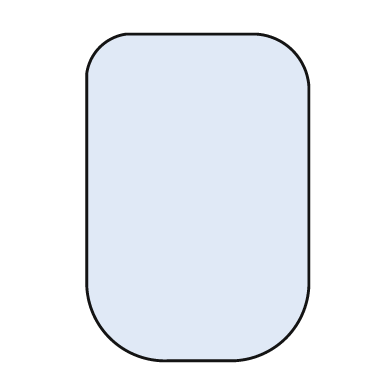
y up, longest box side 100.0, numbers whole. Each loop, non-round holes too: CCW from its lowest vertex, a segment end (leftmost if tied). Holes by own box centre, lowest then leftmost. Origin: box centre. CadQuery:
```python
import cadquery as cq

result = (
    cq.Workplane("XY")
    .moveTo(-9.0, -50.0)
    .lineTo(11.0, -50.0)
    .threePointArc((27.0, -43.0), (34.0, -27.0))
    .lineTo(34.0, 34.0)
    .threePointArc((29.0, 45.0), (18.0, 50.0))
    .lineTo(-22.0, 50.0)
    .threePointArc((-30.0, 46.0), (-34.0, 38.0))
    .lineTo(-34.0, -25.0)
    .threePointArc((-27.0, -43.0), (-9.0, -50.0))
    .close()
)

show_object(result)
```